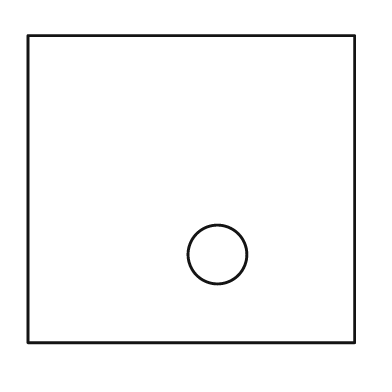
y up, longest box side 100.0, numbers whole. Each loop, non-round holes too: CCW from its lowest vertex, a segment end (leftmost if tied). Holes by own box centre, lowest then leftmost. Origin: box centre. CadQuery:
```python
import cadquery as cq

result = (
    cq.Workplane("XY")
    .moveTo(-50.0, -47.0)
    .lineTo(50.0, -47.0)
    .lineTo(50.0, 47.0)
    .lineTo(-50.0, 47.0)
    .close()
    .moveTo(8.0, -20.0)
    .circle(9.0)
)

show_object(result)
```